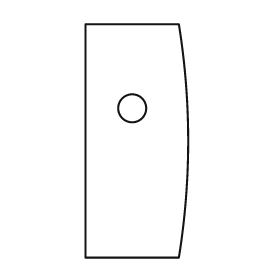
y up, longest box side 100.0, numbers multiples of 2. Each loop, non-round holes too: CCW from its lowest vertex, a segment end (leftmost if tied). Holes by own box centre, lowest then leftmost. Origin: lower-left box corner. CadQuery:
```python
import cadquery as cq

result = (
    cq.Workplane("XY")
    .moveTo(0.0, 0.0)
    .lineTo(40.0, 0.0)
    .threePointArc((44.0, 50.0), (40.0, 100.0))
    .lineTo(0.0, 100.0)
    .close()
    .moveTo(20.0, 64.0)
    .circle(6.0)
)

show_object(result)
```